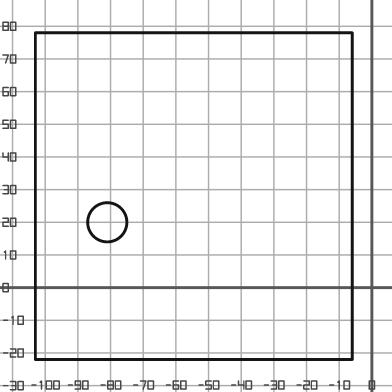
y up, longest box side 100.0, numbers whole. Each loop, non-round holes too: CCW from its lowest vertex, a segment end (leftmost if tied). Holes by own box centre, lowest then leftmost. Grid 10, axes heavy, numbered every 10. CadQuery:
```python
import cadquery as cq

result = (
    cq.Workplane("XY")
    .moveTo(-103.0, -22.0)
    .lineTo(-6.0, -22.0)
    .lineTo(-6.0, 78.0)
    .lineTo(-103.0, 78.0)
    .close()
    .moveTo(-81.0, 20.0)
    .circle(6.0)
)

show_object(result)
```